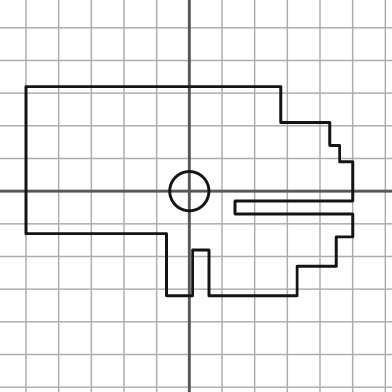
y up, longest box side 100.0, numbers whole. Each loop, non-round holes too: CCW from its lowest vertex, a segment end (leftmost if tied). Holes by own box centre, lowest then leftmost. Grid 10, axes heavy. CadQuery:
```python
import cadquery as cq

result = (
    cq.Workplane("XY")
    .moveTo(-7.0, -32.0)
    .lineTo(1.0, -32.0)
    .lineTo(1.0, -18.0)
    .lineTo(6.0, -18.0)
    .lineTo(6.0, -32.0)
    .lineTo(33.0, -32.0)
    .lineTo(33.0, -23.0)
    .lineTo(45.0, -23.0)
    .lineTo(45.0, -14.0)
    .lineTo(50.0, -14.0)
    .lineTo(50.0, -7.0)
    .lineTo(14.0, -7.0)
    .lineTo(14.0, -3.0)
    .lineTo(50.0, -3.0)
    .lineTo(50.0, 9.0)
    .lineTo(46.0, 9.0)
    .lineTo(46.0, 14.0)
    .lineTo(43.0, 14.0)
    .lineTo(43.0, 21.0)
    .lineTo(28.0, 21.0)
    .lineTo(28.0, 32.0)
    .lineTo(-50.0, 32.0)
    .lineTo(-50.0, -13.0)
    .lineTo(-7.0, -13.0)
    .close()
    .moveTo(0.0, 0.0)
    .circle(6.0)
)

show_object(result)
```